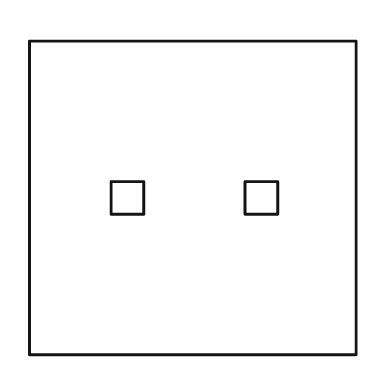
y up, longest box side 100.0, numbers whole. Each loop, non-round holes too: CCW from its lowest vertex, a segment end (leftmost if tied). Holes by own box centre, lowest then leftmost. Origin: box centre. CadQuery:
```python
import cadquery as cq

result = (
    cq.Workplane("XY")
    .moveTo(-50.0, -48.0)
    .lineTo(50.0, -48.0)
    .lineTo(50.0, 48.0)
    .lineTo(-50.0, 48.0)
    .close()
    .moveTo(-25.0, -5.0)
    .lineTo(-15.0, -5.0)
    .lineTo(-15.0, 5.0)
    .lineTo(-25.0, 5.0)
    .close()
    .moveTo(16.0, -5.0)
    .lineTo(26.0, -5.0)
    .lineTo(26.0, 5.0)
    .lineTo(16.0, 5.0)
    .close()
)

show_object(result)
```